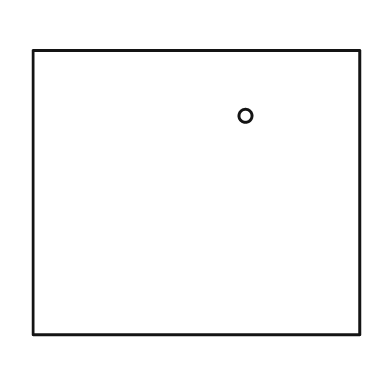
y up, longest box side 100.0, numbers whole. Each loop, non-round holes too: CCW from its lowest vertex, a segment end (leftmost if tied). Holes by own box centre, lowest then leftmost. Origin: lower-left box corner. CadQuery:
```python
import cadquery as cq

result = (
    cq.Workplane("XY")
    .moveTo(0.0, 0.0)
    .lineTo(100.0, 0.0)
    .lineTo(100.0, 87.0)
    .lineTo(0.0, 87.0)
    .close()
    .moveTo(65.0, 67.0)
    .circle(2.0)
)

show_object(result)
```